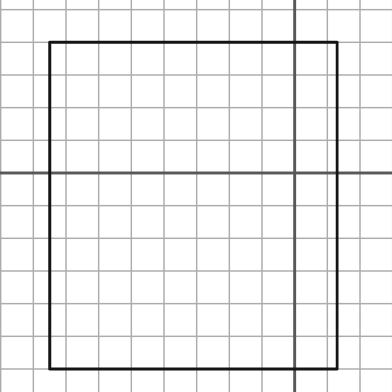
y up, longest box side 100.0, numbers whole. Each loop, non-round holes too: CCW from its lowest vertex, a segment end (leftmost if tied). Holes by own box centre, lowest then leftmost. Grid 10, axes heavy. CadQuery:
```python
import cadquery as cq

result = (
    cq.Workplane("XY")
    .moveTo(-75.0, -60.0)
    .lineTo(13.0, -60.0)
    .lineTo(13.0, 40.0)
    .lineTo(-75.0, 40.0)
    .close()
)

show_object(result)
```